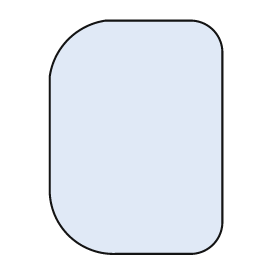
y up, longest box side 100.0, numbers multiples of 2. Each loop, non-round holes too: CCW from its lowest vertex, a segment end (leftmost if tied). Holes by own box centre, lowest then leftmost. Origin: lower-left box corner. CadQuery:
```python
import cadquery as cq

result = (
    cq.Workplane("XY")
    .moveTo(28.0, 0.0)
    .lineTo(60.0, 0.0)
    .threePointArc((70.0, 4.0), (74.0, 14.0))
    .lineTo(74.0, 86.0)
    .threePointArc((70.0, 96.0), (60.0, 100.0))
    .lineTo(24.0, 100.0)
    .threePointArc((8.0, 92.0), (0.0, 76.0))
    .lineTo(0.0, 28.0)
    .threePointArc((8.0, 8.0), (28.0, 0.0))
    .close()
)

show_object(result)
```